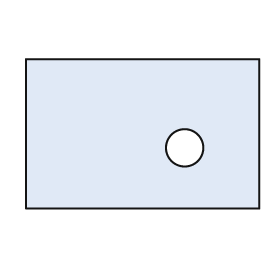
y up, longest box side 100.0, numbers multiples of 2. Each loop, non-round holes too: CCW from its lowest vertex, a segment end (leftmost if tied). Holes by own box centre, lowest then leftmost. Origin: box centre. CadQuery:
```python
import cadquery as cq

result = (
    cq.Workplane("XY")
    .moveTo(-50.0, -32.0)
    .lineTo(50.0, -32.0)
    .lineTo(50.0, 32.0)
    .lineTo(-50.0, 32.0)
    .close()
    .moveTo(18.0, -6.0)
    .circle(8.0)
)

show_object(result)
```